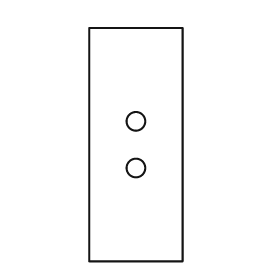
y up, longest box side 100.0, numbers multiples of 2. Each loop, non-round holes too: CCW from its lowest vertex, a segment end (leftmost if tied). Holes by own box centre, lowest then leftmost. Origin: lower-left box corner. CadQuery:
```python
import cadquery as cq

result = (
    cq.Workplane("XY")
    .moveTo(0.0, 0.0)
    .lineTo(40.0, 0.0)
    .lineTo(40.0, 100.0)
    .lineTo(0.0, 100.0)
    .close()
    .moveTo(20.0, 40.0)
    .circle(4.0)
    .moveTo(20.0, 60.0)
    .circle(4.0)
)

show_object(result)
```